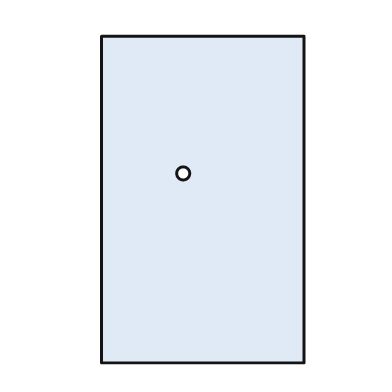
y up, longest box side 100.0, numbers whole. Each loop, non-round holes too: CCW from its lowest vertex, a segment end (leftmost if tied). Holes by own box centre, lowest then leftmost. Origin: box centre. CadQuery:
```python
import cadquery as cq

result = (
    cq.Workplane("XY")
    .moveTo(-31.0, -50.0)
    .lineTo(31.0, -50.0)
    .lineTo(31.0, 50.0)
    .lineTo(-31.0, 50.0)
    .close()
    .moveTo(-6.0, 8.0)
    .circle(2.0)
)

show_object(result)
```